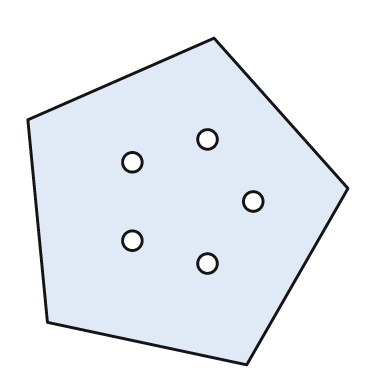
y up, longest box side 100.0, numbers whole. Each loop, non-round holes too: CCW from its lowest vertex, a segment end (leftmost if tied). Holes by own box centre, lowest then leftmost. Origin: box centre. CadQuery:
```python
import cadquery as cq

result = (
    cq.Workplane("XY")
    .moveTo(18.0, -50.0)
    .lineTo(49.0, 4.0)
    .lineTo(8.0, 50.0)
    .lineTo(-49.0, 25.0)
    .lineTo(-43.0, -37.0)
    .close()
    .moveTo(6.0, -19.0)
    .circle(3.0)
    .moveTo(-17.0, -12.0)
    .circle(3.0)
    .moveTo(20.0, 0.0)
    .circle(3.0)
    .moveTo(-17.0, 12.0)
    .circle(3.0)
    .moveTo(6.0, 19.0)
    .circle(3.0)
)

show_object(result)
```